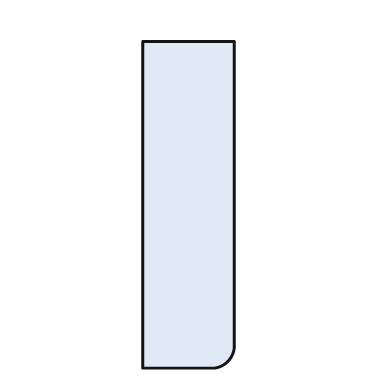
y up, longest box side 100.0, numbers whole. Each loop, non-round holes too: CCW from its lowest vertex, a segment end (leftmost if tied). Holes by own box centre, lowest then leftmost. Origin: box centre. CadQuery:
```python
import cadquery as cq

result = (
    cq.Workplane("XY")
    .moveTo(-14.0, -50.0)
    .lineTo(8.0, -50.0)
    .threePointArc((12.0, -48.0), (14.0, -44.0))
    .lineTo(14.0, 50.0)
    .lineTo(-14.0, 50.0)
    .close()
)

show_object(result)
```